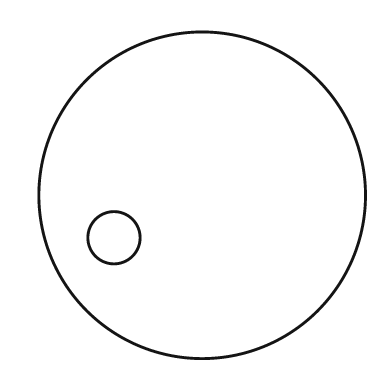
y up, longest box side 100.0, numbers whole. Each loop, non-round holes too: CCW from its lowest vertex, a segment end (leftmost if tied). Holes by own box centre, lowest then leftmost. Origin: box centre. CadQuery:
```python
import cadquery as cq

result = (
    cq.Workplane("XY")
    .moveTo(0.0, 0.0)
    .circle(50.0)
    .moveTo(-27.0, -13.0)
    .circle(8.0)
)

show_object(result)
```